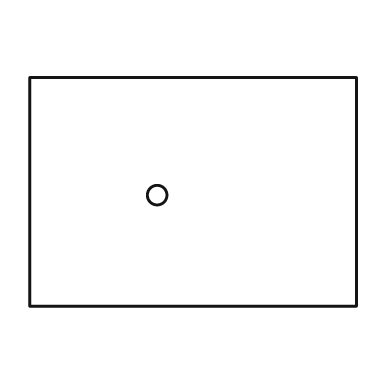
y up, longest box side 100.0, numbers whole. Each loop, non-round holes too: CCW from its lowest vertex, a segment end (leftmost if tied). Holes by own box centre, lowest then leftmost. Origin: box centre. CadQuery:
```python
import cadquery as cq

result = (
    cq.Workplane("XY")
    .moveTo(-50.0, -35.0)
    .lineTo(50.0, -35.0)
    .lineTo(50.0, 35.0)
    .lineTo(-50.0, 35.0)
    .close()
    .moveTo(-11.0, -1.0)
    .circle(3.0)
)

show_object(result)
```